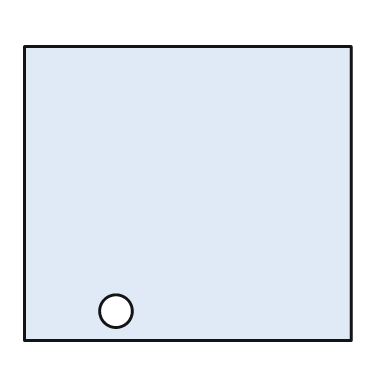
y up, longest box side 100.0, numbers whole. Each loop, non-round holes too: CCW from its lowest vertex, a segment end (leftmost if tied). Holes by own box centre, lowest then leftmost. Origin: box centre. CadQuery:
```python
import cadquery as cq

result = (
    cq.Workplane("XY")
    .moveTo(-50.0, -45.0)
    .lineTo(50.0, -45.0)
    .lineTo(50.0, 45.0)
    .lineTo(-50.0, 45.0)
    .close()
    .moveTo(-22.0, -36.0)
    .circle(5.0)
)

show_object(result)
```